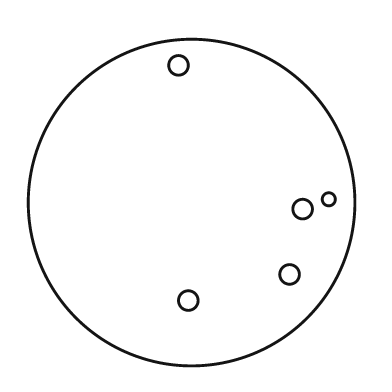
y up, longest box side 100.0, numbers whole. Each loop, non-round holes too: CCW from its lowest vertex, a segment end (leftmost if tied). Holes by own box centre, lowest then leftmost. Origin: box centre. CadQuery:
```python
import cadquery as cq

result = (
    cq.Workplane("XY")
    .moveTo(0.0, 0.0)
    .circle(50.0)
    .moveTo(-1.0, -30.0)
    .circle(3.0)
    .moveTo(30.0, -22.0)
    .circle(3.0)
    .moveTo(34.0, -2.0)
    .circle(3.0)
    .moveTo(42.0, 1.0)
    .circle(2.0)
    .moveTo(-4.0, 42.0)
    .circle(3.0)
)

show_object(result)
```